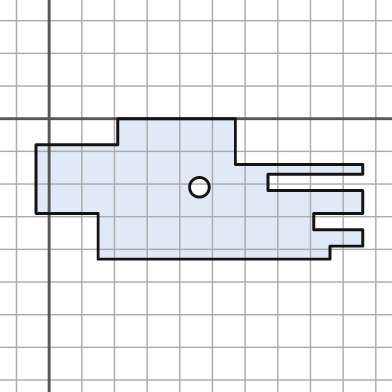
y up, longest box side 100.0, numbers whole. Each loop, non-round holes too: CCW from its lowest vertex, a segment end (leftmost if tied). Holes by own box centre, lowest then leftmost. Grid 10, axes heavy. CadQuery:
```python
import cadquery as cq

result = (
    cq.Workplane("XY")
    .moveTo(15.0, -43.0)
    .lineTo(86.0, -43.0)
    .lineTo(86.0, -39.0)
    .lineTo(96.0, -39.0)
    .lineTo(96.0, -34.0)
    .lineTo(81.0, -34.0)
    .lineTo(81.0, -29.0)
    .lineTo(96.0, -29.0)
    .lineTo(96.0, -22.0)
    .lineTo(67.0, -22.0)
    .lineTo(67.0, -17.0)
    .lineTo(96.0, -17.0)
    .lineTo(96.0, -14.0)
    .lineTo(57.0, -14.0)
    .lineTo(57.0, 0.0)
    .lineTo(21.0, 0.0)
    .lineTo(21.0, -8.0)
    .lineTo(-4.0, -8.0)
    .lineTo(-4.0, -29.0)
    .lineTo(15.0, -29.0)
    .close()
    .moveTo(46.0, -21.0)
    .circle(3.0)
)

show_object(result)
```